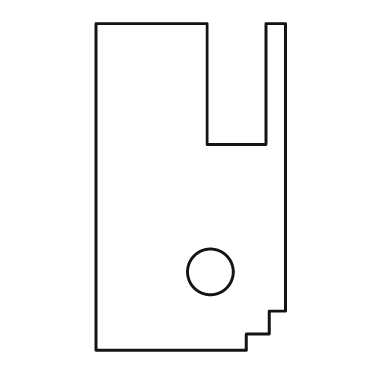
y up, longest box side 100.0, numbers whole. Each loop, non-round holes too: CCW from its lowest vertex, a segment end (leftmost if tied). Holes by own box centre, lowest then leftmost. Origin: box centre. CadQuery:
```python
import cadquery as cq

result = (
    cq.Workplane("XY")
    .moveTo(-29.0, -50.0)
    .lineTo(17.0, -50.0)
    .lineTo(17.0, -45.0)
    .lineTo(24.0, -45.0)
    .lineTo(24.0, -38.0)
    .lineTo(29.0, -38.0)
    .lineTo(29.0, 50.0)
    .lineTo(23.0, 50.0)
    .lineTo(23.0, 13.0)
    .lineTo(5.0, 13.0)
    .lineTo(5.0, 50.0)
    .lineTo(-29.0, 50.0)
    .close()
    .moveTo(6.0, -26.0)
    .circle(7.0)
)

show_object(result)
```